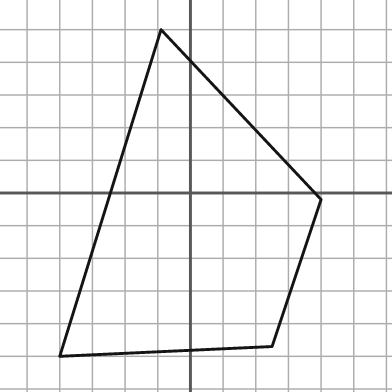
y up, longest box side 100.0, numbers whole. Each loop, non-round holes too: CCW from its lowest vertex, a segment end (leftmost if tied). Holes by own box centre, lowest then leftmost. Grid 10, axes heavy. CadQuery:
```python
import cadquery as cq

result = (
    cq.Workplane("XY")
    .moveTo(-40.0, -50.0)
    .lineTo(25.0, -47.0)
    .lineTo(40.0, -2.0)
    .lineTo(-9.0, 50.0)
    .close()
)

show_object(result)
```